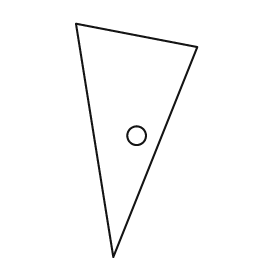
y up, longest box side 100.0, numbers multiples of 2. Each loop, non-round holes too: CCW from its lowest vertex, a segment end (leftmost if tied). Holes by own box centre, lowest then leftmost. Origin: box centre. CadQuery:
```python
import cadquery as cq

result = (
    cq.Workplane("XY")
    .moveTo(-10.0, -50.0)
    .lineTo(26.0, 40.0)
    .lineTo(-26.0, 50.0)
    .close()
    .moveTo(0.0, 2.0)
    .circle(4.0)
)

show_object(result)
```